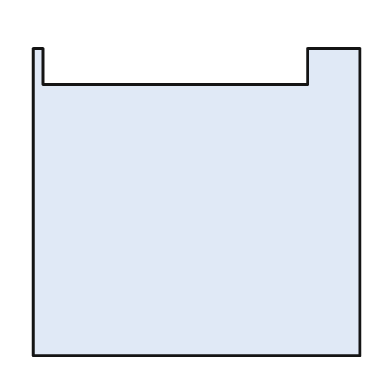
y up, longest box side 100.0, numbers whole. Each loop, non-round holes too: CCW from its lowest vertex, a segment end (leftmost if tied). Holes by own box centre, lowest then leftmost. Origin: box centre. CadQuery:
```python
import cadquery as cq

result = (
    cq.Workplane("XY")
    .moveTo(-50.0, -47.0)
    .lineTo(50.0, -47.0)
    .lineTo(50.0, 47.0)
    .lineTo(34.0, 47.0)
    .lineTo(34.0, 36.0)
    .lineTo(-47.0, 36.0)
    .lineTo(-47.0, 47.0)
    .lineTo(-50.0, 47.0)
    .close()
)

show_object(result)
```